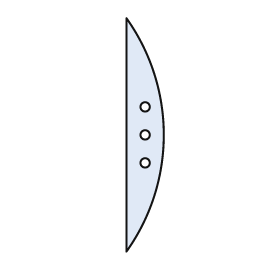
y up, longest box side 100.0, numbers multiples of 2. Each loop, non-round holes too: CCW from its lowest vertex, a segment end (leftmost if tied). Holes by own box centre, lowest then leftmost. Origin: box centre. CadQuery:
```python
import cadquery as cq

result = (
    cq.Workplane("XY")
    .moveTo(-8.0, -50.0)
    .threePointArc((8.0, 0.0), (-8.0, 50.0))
    .close()
    .moveTo(0.0, -12.0)
    .circle(2.0)
    .moveTo(0.0, 0.0)
    .circle(2.0)
    .moveTo(0.0, 12.0)
    .circle(2.0)
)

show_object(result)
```